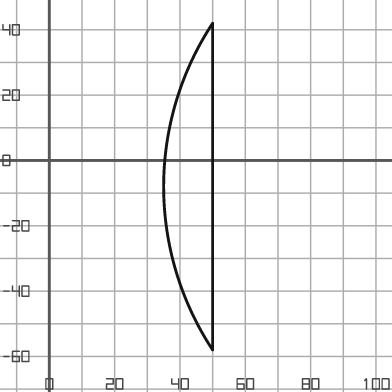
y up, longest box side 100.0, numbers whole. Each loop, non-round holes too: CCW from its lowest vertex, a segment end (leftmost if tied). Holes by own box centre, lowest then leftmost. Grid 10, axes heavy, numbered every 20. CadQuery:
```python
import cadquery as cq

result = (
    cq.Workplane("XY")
    .moveTo(50.0, -58.0)
    .lineTo(50.0, 42.0)
    .threePointArc((35.0, -8.0), (50.0, -58.0))
    .close()
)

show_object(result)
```